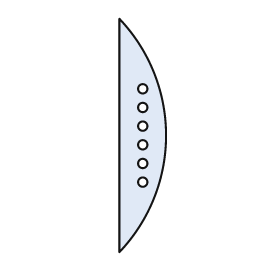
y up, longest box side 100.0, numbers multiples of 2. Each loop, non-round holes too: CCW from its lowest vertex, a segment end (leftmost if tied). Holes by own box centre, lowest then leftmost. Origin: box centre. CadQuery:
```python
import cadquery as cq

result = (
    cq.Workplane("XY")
    .moveTo(-10.0, -50.0)
    .threePointArc((10.0, 0.0), (-10.0, 50.0))
    .close()
    .moveTo(0.0, -20.0)
    .circle(2.0)
    .moveTo(0.0, -12.0)
    .circle(2.0)
    .moveTo(0.0, -4.0)
    .circle(2.0)
    .moveTo(0.0, 4.0)
    .circle(2.0)
    .moveTo(0.0, 12.0)
    .circle(2.0)
    .moveTo(0.0, 20.0)
    .circle(2.0)
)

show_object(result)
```